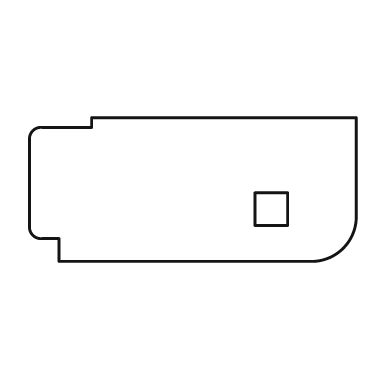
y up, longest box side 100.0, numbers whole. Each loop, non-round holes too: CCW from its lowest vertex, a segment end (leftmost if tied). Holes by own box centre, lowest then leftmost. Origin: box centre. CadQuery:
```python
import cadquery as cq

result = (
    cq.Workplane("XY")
    .moveTo(-41.0, -22.0)
    .lineTo(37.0, -22.0)
    .threePointArc((46.0, -18.0), (50.0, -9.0))
    .lineTo(50.0, 22.0)
    .lineTo(-31.0, 22.0)
    .lineTo(-31.0, 19.0)
    .lineTo(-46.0, 19.0)
    .threePointArc((-49.0, 18.0), (-50.0, 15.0))
    .lineTo(-50.0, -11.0)
    .threePointArc((-49.0, -14.0), (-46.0, -15.0))
    .lineTo(-41.0, -15.0)
    .close()
    .moveTo(19.0, -11.0)
    .lineTo(29.0, -11.0)
    .lineTo(29.0, -1.0)
    .lineTo(19.0, -1.0)
    .close()
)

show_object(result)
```